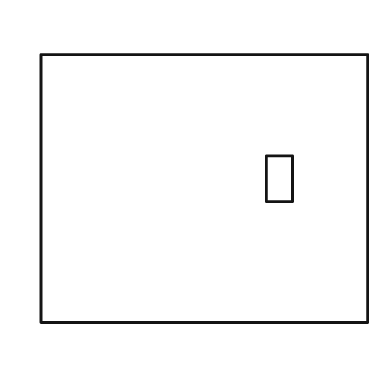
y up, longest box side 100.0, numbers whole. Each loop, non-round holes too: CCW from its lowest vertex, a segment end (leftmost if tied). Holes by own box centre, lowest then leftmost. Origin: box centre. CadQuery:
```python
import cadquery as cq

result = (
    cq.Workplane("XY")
    .moveTo(-50.0, -41.0)
    .lineTo(50.0, -41.0)
    .lineTo(50.0, 41.0)
    .lineTo(-50.0, 41.0)
    .close()
    .moveTo(19.0, -4.0)
    .lineTo(27.0, -4.0)
    .lineTo(27.0, 10.0)
    .lineTo(19.0, 10.0)
    .close()
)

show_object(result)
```